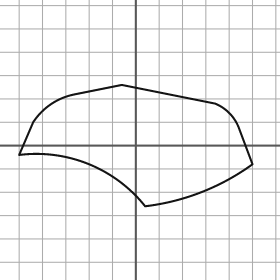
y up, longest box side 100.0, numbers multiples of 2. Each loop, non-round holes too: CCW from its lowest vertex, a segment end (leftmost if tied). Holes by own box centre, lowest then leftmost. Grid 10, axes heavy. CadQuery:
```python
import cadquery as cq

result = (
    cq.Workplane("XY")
    .moveTo(4.0, -26.0)
    .threePointArc((28.0, -20.0), (50.0, -8.0))
    .lineTo(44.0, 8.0)
    .threePointArc((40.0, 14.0), (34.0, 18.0))
    .lineTo(-6.0, 26.0)
    .lineTo(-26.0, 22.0)
    .threePointArc((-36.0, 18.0), (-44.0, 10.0))
    .lineTo(-50.0, -4.0)
    .threePointArc((-20.0, -8.0), (4.0, -26.0))
    .close()
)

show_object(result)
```